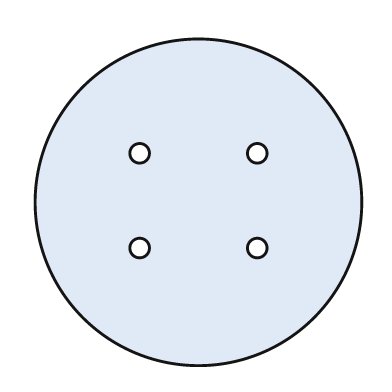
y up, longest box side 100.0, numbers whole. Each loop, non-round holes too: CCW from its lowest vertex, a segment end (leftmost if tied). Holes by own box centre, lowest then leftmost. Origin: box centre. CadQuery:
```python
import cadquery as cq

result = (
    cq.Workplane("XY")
    .moveTo(0.0, 0.0)
    .circle(50.0)
    .moveTo(-18.0, -14.0)
    .circle(3.0)
    .moveTo(18.0, -14.0)
    .circle(3.0)
    .moveTo(-18.0, 15.0)
    .circle(3.0)
    .moveTo(18.0, 15.0)
    .circle(3.0)
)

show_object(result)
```